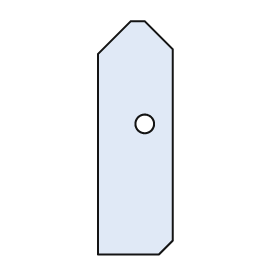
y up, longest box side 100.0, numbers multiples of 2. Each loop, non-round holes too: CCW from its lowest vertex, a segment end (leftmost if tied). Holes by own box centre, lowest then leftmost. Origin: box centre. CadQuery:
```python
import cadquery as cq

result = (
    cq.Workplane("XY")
    .moveTo(-16.0, -50.0)
    .lineTo(10.0, -50.0)
    .lineTo(16.0, -44.0)
    .lineTo(16.0, 38.0)
    .lineTo(4.0, 50.0)
    .lineTo(-2.0, 50.0)
    .lineTo(-16.0, 36.0)
    .close()
    .moveTo(4.0, 6.0)
    .circle(4.0)
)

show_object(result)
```